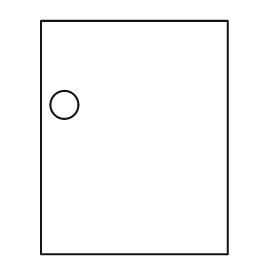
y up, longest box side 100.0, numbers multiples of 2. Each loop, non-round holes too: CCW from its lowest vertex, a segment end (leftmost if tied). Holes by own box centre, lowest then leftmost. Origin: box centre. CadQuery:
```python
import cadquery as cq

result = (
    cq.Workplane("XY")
    .moveTo(-40.0, -50.0)
    .lineTo(40.0, -50.0)
    .lineTo(40.0, 50.0)
    .lineTo(-40.0, 50.0)
    .close()
    .moveTo(-30.0, 14.0)
    .circle(6.0)
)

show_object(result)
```